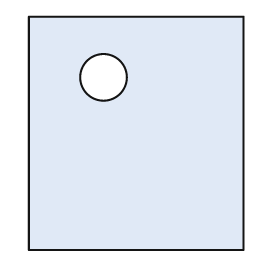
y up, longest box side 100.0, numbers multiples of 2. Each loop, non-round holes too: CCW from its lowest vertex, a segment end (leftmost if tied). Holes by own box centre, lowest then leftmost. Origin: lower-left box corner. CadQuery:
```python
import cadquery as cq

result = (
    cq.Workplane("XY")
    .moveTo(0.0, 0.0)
    .lineTo(92.0, 0.0)
    .lineTo(92.0, 100.0)
    .lineTo(0.0, 100.0)
    .close()
    .moveTo(32.0, 74.0)
    .circle(10.0)
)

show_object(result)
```